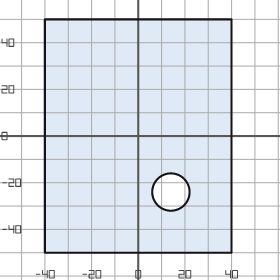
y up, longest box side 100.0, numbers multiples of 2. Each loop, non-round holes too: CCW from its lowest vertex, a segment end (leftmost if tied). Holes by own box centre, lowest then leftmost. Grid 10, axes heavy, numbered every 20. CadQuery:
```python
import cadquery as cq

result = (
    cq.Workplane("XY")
    .moveTo(-40.0, -50.0)
    .lineTo(40.0, -50.0)
    .lineTo(40.0, 50.0)
    .lineTo(-40.0, 50.0)
    .close()
    .moveTo(14.0, -24.0)
    .circle(8.0)
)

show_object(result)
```